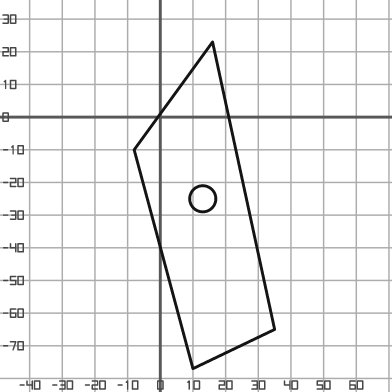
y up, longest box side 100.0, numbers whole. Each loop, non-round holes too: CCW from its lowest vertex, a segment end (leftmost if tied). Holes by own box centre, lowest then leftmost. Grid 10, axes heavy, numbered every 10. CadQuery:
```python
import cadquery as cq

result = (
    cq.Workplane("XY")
    .moveTo(10.0, -77.0)
    .lineTo(35.0, -65.0)
    .lineTo(16.0, 23.0)
    .lineTo(-8.0, -10.0)
    .close()
    .moveTo(13.0, -25.0)
    .circle(4.0)
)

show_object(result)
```